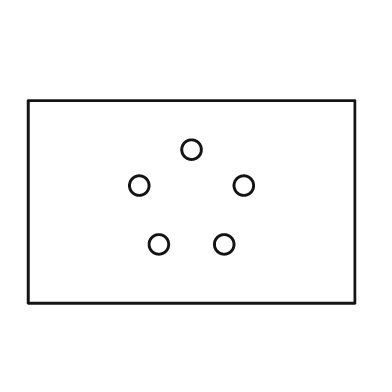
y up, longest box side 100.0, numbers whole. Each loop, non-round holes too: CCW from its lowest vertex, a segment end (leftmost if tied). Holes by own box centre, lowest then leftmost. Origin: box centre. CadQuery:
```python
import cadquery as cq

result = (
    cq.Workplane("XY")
    .moveTo(-50.0, -31.0)
    .lineTo(50.0, -31.0)
    .lineTo(50.0, 31.0)
    .lineTo(-50.0, 31.0)
    .close()
    .moveTo(-10.0, -13.0)
    .circle(3.0)
    .moveTo(10.0, -13.0)
    .circle(3.0)
    .moveTo(-16.0, 5.0)
    .circle(3.0)
    .moveTo(16.0, 5.0)
    .circle(3.0)
    .moveTo(0.0, 16.0)
    .circle(3.0)
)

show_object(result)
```